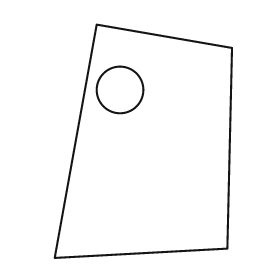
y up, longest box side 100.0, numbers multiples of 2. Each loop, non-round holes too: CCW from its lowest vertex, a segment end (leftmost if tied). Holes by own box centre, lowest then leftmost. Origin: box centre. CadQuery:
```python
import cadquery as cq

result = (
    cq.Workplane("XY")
    .moveTo(-38.0, -50.0)
    .lineTo(36.0, -46.0)
    .lineTo(38.0, 40.0)
    .lineTo(-20.0, 50.0)
    .close()
    .moveTo(-10.0, 22.0)
    .circle(10.0)
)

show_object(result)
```